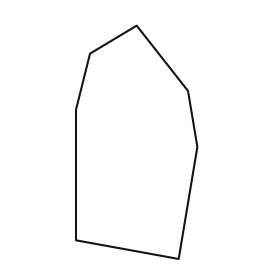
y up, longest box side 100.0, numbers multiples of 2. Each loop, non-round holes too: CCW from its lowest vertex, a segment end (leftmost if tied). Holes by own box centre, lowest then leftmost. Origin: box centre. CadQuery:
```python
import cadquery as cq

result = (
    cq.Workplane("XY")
    .moveTo(18.0, -50.0)
    .lineTo(26.0, -2.0)
    .lineTo(22.0, 22.0)
    .lineTo(0.0, 50.0)
    .lineTo(-20.0, 38.0)
    .lineTo(-26.0, 14.0)
    .lineTo(-26.0, -42.0)
    .close()
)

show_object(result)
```